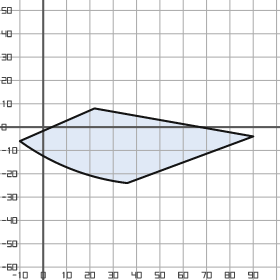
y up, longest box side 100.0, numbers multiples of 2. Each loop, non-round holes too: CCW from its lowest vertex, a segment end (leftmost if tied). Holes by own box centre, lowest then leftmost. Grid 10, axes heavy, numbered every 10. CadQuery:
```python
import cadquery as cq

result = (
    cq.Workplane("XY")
    .moveTo(36.0, -24.0)
    .lineTo(90.0, -4.0)
    .lineTo(22.0, 8.0)
    .lineTo(-10.0, -6.0)
    .threePointArc((12.0, -18.0), (36.0, -24.0))
    .close()
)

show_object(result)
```